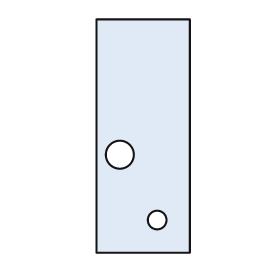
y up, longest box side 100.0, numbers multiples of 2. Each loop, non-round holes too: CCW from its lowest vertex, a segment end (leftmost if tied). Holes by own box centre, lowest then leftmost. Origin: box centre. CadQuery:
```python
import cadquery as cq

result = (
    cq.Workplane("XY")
    .moveTo(-20.0, -50.0)
    .lineTo(20.0, -50.0)
    .lineTo(20.0, 50.0)
    .lineTo(-20.0, 50.0)
    .close()
    .moveTo(6.0, -36.0)
    .circle(4.0)
    .moveTo(-10.0, -8.0)
    .circle(6.0)
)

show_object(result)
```